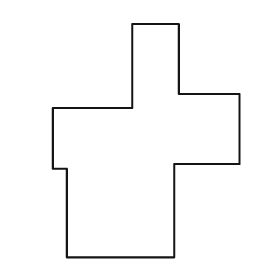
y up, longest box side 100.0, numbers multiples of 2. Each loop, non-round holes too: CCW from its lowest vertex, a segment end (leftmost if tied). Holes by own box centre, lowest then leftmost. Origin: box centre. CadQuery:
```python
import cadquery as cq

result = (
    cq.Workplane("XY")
    .moveTo(-34.0, -50.0)
    .lineTo(12.0, -50.0)
    .lineTo(12.0, -10.0)
    .lineTo(40.0, -10.0)
    .lineTo(40.0, 20.0)
    .lineTo(14.0, 20.0)
    .lineTo(14.0, 50.0)
    .lineTo(-6.0, 50.0)
    .lineTo(-6.0, 14.0)
    .lineTo(-40.0, 14.0)
    .lineTo(-40.0, -12.0)
    .lineTo(-34.0, -12.0)
    .close()
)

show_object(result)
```